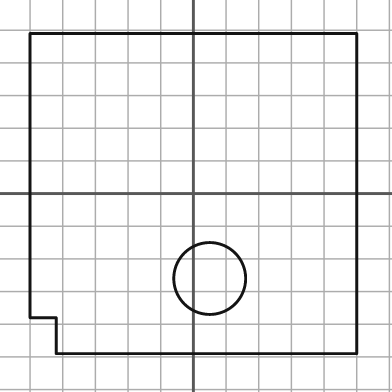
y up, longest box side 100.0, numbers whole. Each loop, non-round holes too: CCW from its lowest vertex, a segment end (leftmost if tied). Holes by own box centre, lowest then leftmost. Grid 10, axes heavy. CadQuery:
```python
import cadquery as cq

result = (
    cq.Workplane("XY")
    .moveTo(-42.0, -49.0)
    .lineTo(50.0, -49.0)
    .lineTo(50.0, 49.0)
    .lineTo(-50.0, 49.0)
    .lineTo(-50.0, -38.0)
    .lineTo(-42.0, -38.0)
    .close()
    .moveTo(5.0, -26.0)
    .circle(11.0)
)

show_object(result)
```